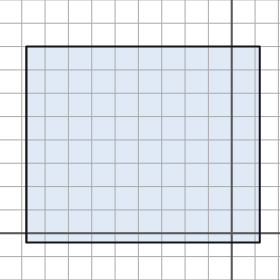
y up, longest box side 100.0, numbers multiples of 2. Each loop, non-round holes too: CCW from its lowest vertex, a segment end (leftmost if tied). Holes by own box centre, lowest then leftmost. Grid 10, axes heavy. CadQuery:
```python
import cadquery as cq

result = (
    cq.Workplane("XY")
    .moveTo(-88.0, -4.0)
    .lineTo(12.0, -4.0)
    .lineTo(12.0, 80.0)
    .lineTo(-88.0, 80.0)
    .close()
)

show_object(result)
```